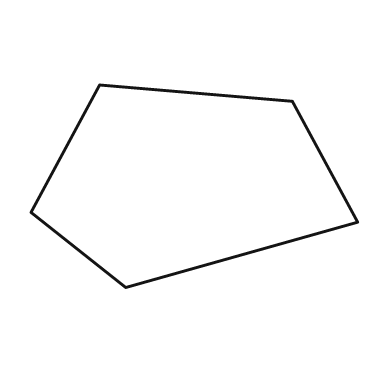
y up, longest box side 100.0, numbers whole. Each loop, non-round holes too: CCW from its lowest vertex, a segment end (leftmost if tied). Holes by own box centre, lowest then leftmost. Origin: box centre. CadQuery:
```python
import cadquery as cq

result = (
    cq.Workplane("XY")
    .moveTo(-21.0, -31.0)
    .lineTo(50.0, -11.0)
    .lineTo(30.0, 26.0)
    .lineTo(-29.0, 31.0)
    .lineTo(-50.0, -8.0)
    .close()
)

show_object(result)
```